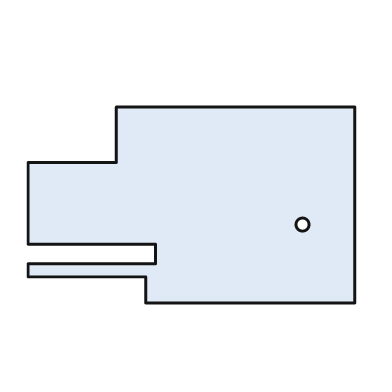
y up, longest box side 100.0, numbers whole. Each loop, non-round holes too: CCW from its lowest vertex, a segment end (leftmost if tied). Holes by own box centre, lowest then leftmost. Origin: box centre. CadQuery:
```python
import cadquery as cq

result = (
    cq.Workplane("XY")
    .moveTo(-14.0, -30.0)
    .lineTo(50.0, -30.0)
    .lineTo(50.0, 30.0)
    .lineTo(-23.0, 30.0)
    .lineTo(-23.0, 13.0)
    .lineTo(-50.0, 13.0)
    .lineTo(-50.0, -12.0)
    .lineTo(-11.0, -12.0)
    .lineTo(-11.0, -18.0)
    .lineTo(-50.0, -18.0)
    .lineTo(-50.0, -22.0)
    .lineTo(-14.0, -22.0)
    .close()
    .moveTo(34.0, -6.0)
    .circle(2.0)
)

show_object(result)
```